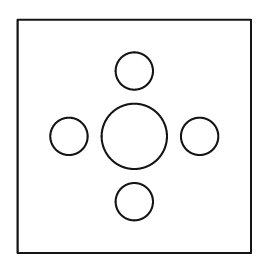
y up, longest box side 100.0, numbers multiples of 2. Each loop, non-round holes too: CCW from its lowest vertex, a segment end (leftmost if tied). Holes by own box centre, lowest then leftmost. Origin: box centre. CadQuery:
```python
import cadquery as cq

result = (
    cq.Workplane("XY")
    .moveTo(-50.0, -50.0)
    .lineTo(50.0, -50.0)
    .lineTo(50.0, 50.0)
    .lineTo(-50.0, 50.0)
    .close()
    .moveTo(0.0, -28.0)
    .circle(8.0)
    .moveTo(-28.0, 0.0)
    .circle(8.0)
    .moveTo(0.0, 0.0)
    .circle(14.0)
    .moveTo(28.0, 0.0)
    .circle(8.0)
    .moveTo(0.0, 28.0)
    .circle(8.0)
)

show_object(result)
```